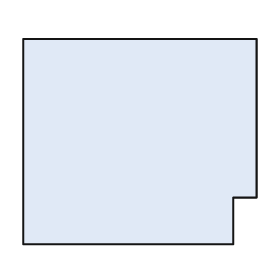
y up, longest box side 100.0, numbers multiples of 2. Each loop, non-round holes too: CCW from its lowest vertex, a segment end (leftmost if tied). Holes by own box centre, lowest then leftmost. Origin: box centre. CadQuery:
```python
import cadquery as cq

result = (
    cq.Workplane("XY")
    .moveTo(-50.0, -44.0)
    .lineTo(40.0, -44.0)
    .lineTo(40.0, -24.0)
    .lineTo(50.0, -24.0)
    .lineTo(50.0, 44.0)
    .lineTo(-50.0, 44.0)
    .close()
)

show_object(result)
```